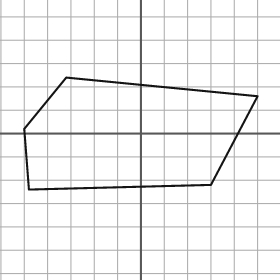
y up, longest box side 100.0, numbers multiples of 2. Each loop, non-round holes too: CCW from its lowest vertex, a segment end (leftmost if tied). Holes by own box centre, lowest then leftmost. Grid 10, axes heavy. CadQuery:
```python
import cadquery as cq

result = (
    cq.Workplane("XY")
    .moveTo(-48.0, -24.0)
    .lineTo(30.0, -22.0)
    .lineTo(50.0, 16.0)
    .lineTo(-32.0, 24.0)
    .lineTo(-50.0, 2.0)
    .close()
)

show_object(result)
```